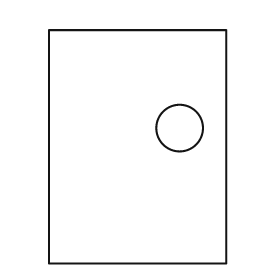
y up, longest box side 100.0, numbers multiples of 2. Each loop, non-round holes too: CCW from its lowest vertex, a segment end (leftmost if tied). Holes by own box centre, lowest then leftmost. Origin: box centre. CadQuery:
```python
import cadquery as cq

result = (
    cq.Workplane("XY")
    .moveTo(-38.0, -50.0)
    .lineTo(38.0, -50.0)
    .lineTo(38.0, 50.0)
    .lineTo(-38.0, 50.0)
    .close()
    .moveTo(18.0, 8.0)
    .circle(10.0)
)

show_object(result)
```